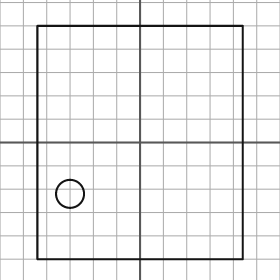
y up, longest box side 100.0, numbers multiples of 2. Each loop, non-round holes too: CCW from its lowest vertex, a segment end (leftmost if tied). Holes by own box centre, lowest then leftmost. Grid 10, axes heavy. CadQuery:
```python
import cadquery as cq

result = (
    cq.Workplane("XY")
    .moveTo(-44.0, -50.0)
    .lineTo(44.0, -50.0)
    .lineTo(44.0, 50.0)
    .lineTo(-44.0, 50.0)
    .close()
    .moveTo(-30.0, -22.0)
    .circle(6.0)
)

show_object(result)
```